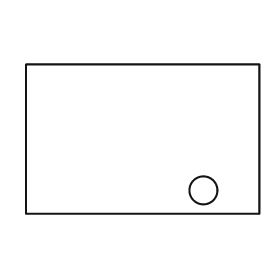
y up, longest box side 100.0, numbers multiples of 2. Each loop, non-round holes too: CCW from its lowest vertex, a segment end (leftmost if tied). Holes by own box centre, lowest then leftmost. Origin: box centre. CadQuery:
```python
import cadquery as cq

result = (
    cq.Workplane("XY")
    .moveTo(-50.0, -32.0)
    .lineTo(50.0, -32.0)
    .lineTo(50.0, 32.0)
    .lineTo(-50.0, 32.0)
    .close()
    .moveTo(26.0, -22.0)
    .circle(6.0)
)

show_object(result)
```